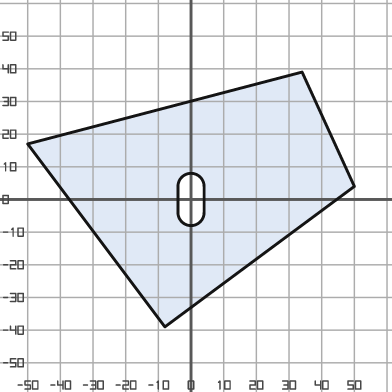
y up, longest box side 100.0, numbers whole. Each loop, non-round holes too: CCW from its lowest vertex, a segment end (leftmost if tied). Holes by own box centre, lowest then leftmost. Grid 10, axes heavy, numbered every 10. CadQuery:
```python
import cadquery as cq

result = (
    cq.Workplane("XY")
    .moveTo(-8.0, -39.0)
    .lineTo(50.0, 4.0)
    .lineTo(34.0, 39.0)
    .lineTo(-50.0, 17.0)
    .close()
    .moveTo(-4.0, -4.0)
    .threePointArc((0.0, -8.0), (4.0, -4.0))
    .lineTo(4.0, 4.0)
    .threePointArc((0.0, 8.0), (-4.0, 4.0))
    .close()
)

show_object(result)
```